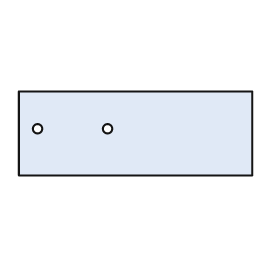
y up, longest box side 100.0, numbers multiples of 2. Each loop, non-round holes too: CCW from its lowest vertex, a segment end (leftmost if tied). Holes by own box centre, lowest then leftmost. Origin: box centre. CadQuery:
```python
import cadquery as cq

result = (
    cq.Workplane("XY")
    .moveTo(-50.0, -18.0)
    .lineTo(50.0, -18.0)
    .lineTo(50.0, 18.0)
    .lineTo(-50.0, 18.0)
    .close()
    .moveTo(-42.0, 2.0)
    .circle(2.0)
    .moveTo(-12.0, 2.0)
    .circle(2.0)
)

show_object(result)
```